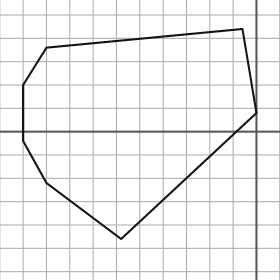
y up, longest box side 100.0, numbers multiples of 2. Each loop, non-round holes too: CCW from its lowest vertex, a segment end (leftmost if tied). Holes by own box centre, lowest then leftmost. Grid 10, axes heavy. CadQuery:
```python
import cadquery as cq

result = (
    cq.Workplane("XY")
    .moveTo(-58.0, -46.0)
    .lineTo(0.0, 8.0)
    .lineTo(-6.0, 44.0)
    .lineTo(-90.0, 36.0)
    .lineTo(-100.0, 20.0)
    .lineTo(-100.0, -4.0)
    .lineTo(-90.0, -22.0)
    .close()
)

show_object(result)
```